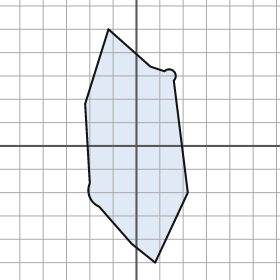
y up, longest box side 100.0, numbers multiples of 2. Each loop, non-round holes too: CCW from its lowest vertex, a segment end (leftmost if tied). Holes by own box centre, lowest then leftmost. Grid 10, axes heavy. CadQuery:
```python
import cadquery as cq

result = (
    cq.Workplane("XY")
    .moveTo(8.0, -50.0)
    .lineTo(22.0, -20.0)
    .lineTo(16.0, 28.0)
    .threePointArc((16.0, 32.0), (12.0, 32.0))
    .lineTo(6.0, 34.0)
    .lineTo(-12.0, 50.0)
    .lineTo(-22.0, 18.0)
    .lineTo(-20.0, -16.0)
    .threePointArc((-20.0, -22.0), (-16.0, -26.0))
    .lineTo(-2.0, -42.0)
    .close()
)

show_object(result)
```